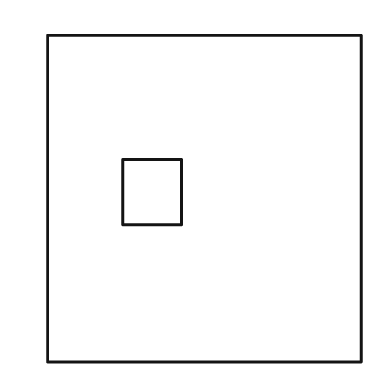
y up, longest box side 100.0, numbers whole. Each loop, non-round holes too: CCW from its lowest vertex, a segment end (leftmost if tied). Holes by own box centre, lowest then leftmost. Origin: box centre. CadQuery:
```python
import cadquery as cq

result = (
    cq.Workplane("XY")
    .moveTo(-48.0, -50.0)
    .lineTo(48.0, -50.0)
    .lineTo(48.0, 50.0)
    .lineTo(-48.0, 50.0)
    .close()
    .moveTo(-25.0, -8.0)
    .lineTo(-7.0, -8.0)
    .lineTo(-7.0, 12.0)
    .lineTo(-25.0, 12.0)
    .close()
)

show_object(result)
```